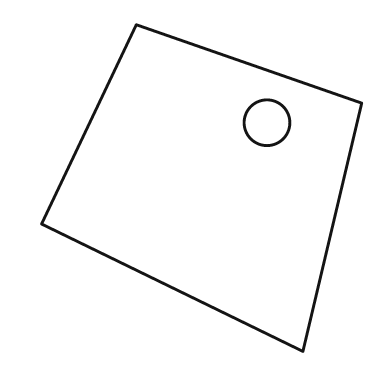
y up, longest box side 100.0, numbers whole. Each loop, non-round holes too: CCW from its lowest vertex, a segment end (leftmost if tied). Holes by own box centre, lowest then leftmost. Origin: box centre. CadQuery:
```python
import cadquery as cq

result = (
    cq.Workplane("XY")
    .moveTo(31.0, -50.0)
    .lineTo(49.0, 26.0)
    .lineTo(-20.0, 50.0)
    .lineTo(-49.0, -11.0)
    .close()
    .moveTo(20.0, 20.0)
    .circle(7.0)
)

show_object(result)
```